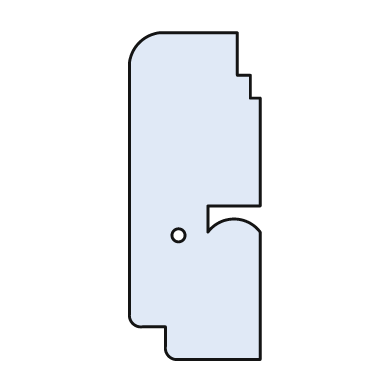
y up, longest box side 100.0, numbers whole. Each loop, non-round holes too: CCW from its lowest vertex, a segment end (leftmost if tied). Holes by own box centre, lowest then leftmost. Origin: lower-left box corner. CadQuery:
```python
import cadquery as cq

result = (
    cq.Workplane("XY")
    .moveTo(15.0, 0.0)
    .lineTo(40.0, 0.0)
    .lineTo(40.0, 39.0)
    .threePointArc((32.0, 43.0), (24.0, 39.0))
    .lineTo(24.0, 47.0)
    .lineTo(40.0, 47.0)
    .lineTo(40.0, 80.0)
    .lineTo(37.0, 80.0)
    .lineTo(37.0, 87.0)
    .lineTo(33.0, 87.0)
    .lineTo(33.0, 100.0)
    .lineTo(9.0, 100.0)
    .threePointArc((3.0, 97.0), (0.0, 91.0))
    .lineTo(0.0, 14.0)
    .threePointArc((1.0, 11.0), (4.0, 10.0))
    .lineTo(11.0, 10.0)
    .lineTo(11.0, 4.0)
    .threePointArc((12.0, 1.0), (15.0, 0.0))
    .close()
    .moveTo(15.0, 38.0)
    .circle(2.0)
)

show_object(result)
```